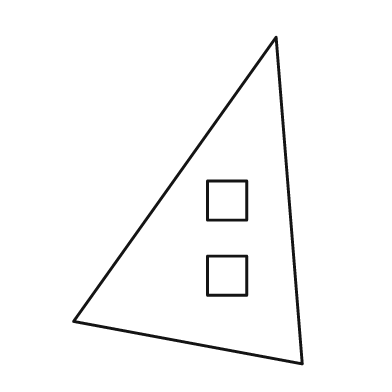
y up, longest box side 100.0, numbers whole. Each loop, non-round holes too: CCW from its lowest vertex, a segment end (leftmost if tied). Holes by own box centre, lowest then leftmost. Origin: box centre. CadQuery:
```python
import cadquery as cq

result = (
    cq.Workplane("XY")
    .moveTo(35.0, -50.0)
    .lineTo(27.0, 50.0)
    .lineTo(-35.0, -37.0)
    .close()
    .moveTo(6.0, -29.0)
    .lineTo(18.0, -29.0)
    .lineTo(18.0, -17.0)
    .lineTo(6.0, -17.0)
    .close()
    .moveTo(6.0, -6.0)
    .lineTo(18.0, -6.0)
    .lineTo(18.0, 6.0)
    .lineTo(6.0, 6.0)
    .close()
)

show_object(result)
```